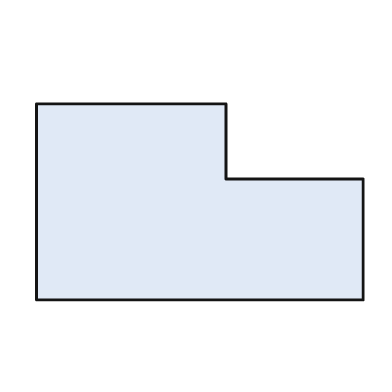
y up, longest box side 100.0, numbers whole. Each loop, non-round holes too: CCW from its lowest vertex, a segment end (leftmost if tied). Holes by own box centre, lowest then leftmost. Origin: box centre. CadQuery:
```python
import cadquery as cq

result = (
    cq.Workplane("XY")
    .moveTo(-50.0, -30.0)
    .lineTo(50.0, -30.0)
    .lineTo(50.0, 7.0)
    .lineTo(8.0, 7.0)
    .lineTo(8.0, 30.0)
    .lineTo(-50.0, 30.0)
    .close()
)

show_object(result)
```